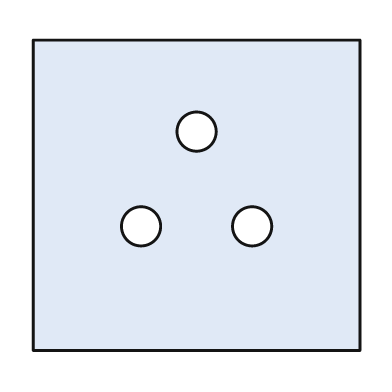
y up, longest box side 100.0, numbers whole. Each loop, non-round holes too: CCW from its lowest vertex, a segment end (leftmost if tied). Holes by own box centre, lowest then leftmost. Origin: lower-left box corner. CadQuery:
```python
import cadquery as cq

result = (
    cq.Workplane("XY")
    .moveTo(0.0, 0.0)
    .lineTo(100.0, 0.0)
    .lineTo(100.0, 95.0)
    .lineTo(0.0, 95.0)
    .close()
    .moveTo(33.0, 38.0)
    .circle(6.0)
    .moveTo(67.0, 38.0)
    .circle(6.0)
    .moveTo(50.0, 67.0)
    .circle(6.0)
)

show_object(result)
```